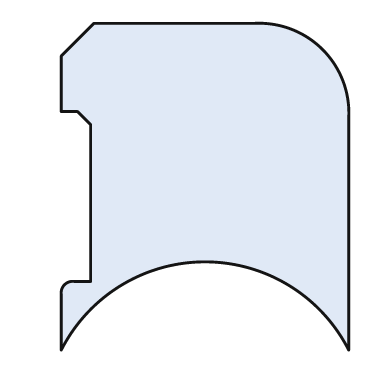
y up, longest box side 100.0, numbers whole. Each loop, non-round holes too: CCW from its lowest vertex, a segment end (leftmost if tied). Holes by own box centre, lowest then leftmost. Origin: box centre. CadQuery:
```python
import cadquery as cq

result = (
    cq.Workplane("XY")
    .moveTo(-44.0, -50.0)
    .threePointArc((0.0, -23.0), (44.0, -50.0))
    .lineTo(44.0, 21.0)
    .threePointArc((36.0, 42.0), (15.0, 50.0))
    .lineTo(-34.0, 50.0)
    .lineTo(-44.0, 40.0)
    .lineTo(-44.0, 23.0)
    .lineTo(-39.0, 23.0)
    .lineTo(-35.0, 19.0)
    .lineTo(-35.0, -29.0)
    .lineTo(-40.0, -29.0)
    .threePointArc((-43.0, -30.0), (-44.0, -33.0))
    .close()
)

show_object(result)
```